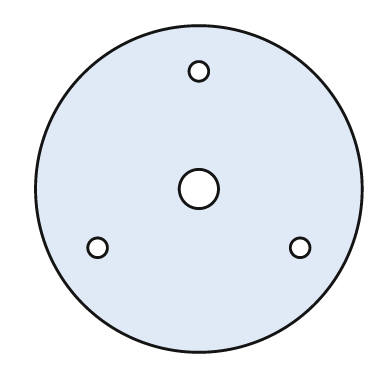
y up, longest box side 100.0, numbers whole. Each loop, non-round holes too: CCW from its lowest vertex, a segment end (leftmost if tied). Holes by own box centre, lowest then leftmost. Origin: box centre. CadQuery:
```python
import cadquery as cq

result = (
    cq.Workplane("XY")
    .moveTo(0.0, 0.0)
    .circle(50.0)
    .moveTo(-31.0, -18.0)
    .circle(3.0)
    .moveTo(31.0, -18.0)
    .circle(3.0)
    .moveTo(0.0, 0.0)
    .circle(6.0)
    .moveTo(0.0, 36.0)
    .circle(3.0)
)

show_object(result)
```